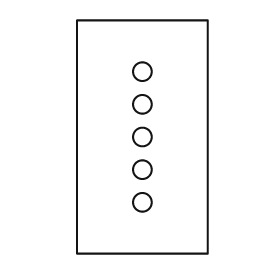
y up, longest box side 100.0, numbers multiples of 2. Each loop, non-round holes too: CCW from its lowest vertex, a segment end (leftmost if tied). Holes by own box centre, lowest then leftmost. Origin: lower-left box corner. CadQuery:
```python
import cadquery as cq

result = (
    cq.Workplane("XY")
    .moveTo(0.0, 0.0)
    .lineTo(56.0, 0.0)
    .lineTo(56.0, 100.0)
    .lineTo(0.0, 100.0)
    .close()
    .moveTo(28.0, 22.0)
    .circle(4.0)
    .moveTo(28.0, 36.0)
    .circle(4.0)
    .moveTo(28.0, 50.0)
    .circle(4.0)
    .moveTo(28.0, 64.0)
    .circle(4.0)
    .moveTo(28.0, 78.0)
    .circle(4.0)
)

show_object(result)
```